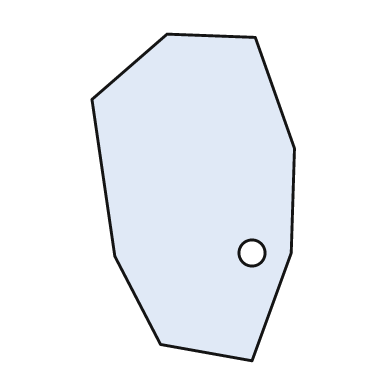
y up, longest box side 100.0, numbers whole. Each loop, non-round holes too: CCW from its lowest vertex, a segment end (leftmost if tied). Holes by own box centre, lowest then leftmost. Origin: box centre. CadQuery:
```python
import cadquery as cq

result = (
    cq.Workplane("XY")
    .moveTo(18.0, -50.0)
    .lineTo(30.0, -17.0)
    .lineTo(31.0, 15.0)
    .lineTo(19.0, 49.0)
    .lineTo(-8.0, 50.0)
    .lineTo(-31.0, 30.0)
    .lineTo(-24.0, -18.0)
    .lineTo(-10.0, -45.0)
    .close()
    .moveTo(18.0, -17.0)
    .circle(4.0)
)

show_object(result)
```